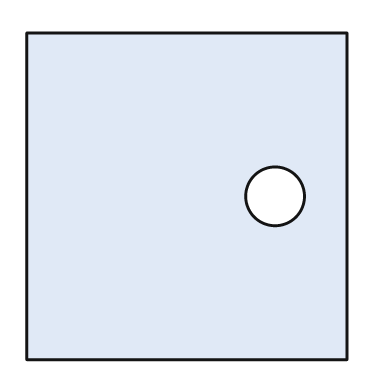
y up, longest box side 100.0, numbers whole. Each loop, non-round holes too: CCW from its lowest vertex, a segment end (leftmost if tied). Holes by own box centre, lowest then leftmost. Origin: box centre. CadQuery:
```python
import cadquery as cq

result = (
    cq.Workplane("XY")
    .moveTo(-49.0, -50.0)
    .lineTo(49.0, -50.0)
    .lineTo(49.0, 50.0)
    .lineTo(-49.0, 50.0)
    .close()
    .moveTo(27.0, 0.0)
    .circle(9.0)
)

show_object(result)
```